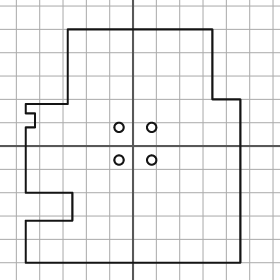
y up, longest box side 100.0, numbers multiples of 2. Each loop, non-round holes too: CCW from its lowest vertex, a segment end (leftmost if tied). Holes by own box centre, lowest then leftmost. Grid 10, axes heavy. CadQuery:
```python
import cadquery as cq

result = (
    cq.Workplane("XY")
    .moveTo(-46.0, -50.0)
    .lineTo(46.0, -50.0)
    .lineTo(46.0, 20.0)
    .lineTo(34.0, 20.0)
    .lineTo(34.0, 50.0)
    .lineTo(-28.0, 50.0)
    .lineTo(-28.0, 18.0)
    .lineTo(-46.0, 18.0)
    .lineTo(-46.0, 14.0)
    .lineTo(-42.0, 14.0)
    .lineTo(-42.0, 8.0)
    .lineTo(-46.0, 8.0)
    .lineTo(-46.0, -20.0)
    .lineTo(-26.0, -20.0)
    .lineTo(-26.0, -32.0)
    .lineTo(-46.0, -32.0)
    .close()
    .moveTo(-6.0, -6.0)
    .circle(2.0)
    .moveTo(8.0, -6.0)
    .circle(2.0)
    .moveTo(-6.0, 8.0)
    .circle(2.0)
    .moveTo(8.0, 8.0)
    .circle(2.0)
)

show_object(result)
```